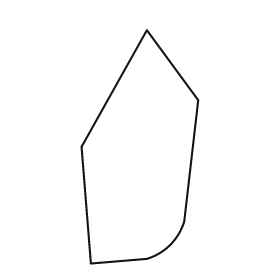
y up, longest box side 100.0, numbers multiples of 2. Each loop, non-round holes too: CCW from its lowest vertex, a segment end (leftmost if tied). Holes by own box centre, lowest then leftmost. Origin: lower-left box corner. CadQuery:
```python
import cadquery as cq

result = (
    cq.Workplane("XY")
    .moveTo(4.0, 0.0)
    .lineTo(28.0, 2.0)
    .threePointArc((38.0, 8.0), (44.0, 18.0))
    .lineTo(50.0, 70.0)
    .lineTo(28.0, 100.0)
    .lineTo(0.0, 50.0)
    .close()
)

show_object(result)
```